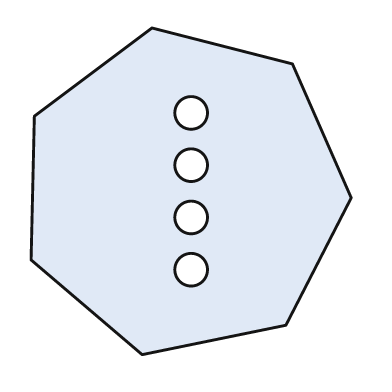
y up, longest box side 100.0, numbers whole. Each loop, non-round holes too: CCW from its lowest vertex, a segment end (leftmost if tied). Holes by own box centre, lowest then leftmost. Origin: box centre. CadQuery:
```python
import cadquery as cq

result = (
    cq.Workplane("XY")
    .moveTo(-15.0, -50.0)
    .lineTo(29.0, -41.0)
    .lineTo(49.0, -2.0)
    .lineTo(31.0, 39.0)
    .lineTo(-12.0, 50.0)
    .lineTo(-48.0, 23.0)
    .lineTo(-49.0, -21.0)
    .close()
    .moveTo(0.0, -24.0)
    .circle(5.0)
    .moveTo(0.0, -8.0)
    .circle(5.0)
    .moveTo(0.0, 8.0)
    .circle(5.0)
    .moveTo(0.0, 24.0)
    .circle(5.0)
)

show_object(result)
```